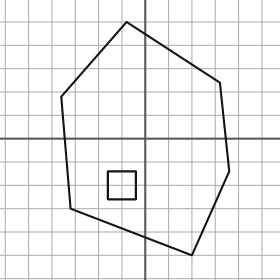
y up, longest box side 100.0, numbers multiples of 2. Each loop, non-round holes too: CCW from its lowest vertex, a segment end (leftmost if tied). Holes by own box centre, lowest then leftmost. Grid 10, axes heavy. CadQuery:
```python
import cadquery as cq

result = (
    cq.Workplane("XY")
    .moveTo(20.0, -50.0)
    .lineTo(36.0, -14.0)
    .lineTo(32.0, 24.0)
    .lineTo(-8.0, 50.0)
    .lineTo(-36.0, 18.0)
    .lineTo(-32.0, -30.0)
    .close()
    .moveTo(-16.0, -26.0)
    .lineTo(-4.0, -26.0)
    .lineTo(-4.0, -14.0)
    .lineTo(-16.0, -14.0)
    .close()
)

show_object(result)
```